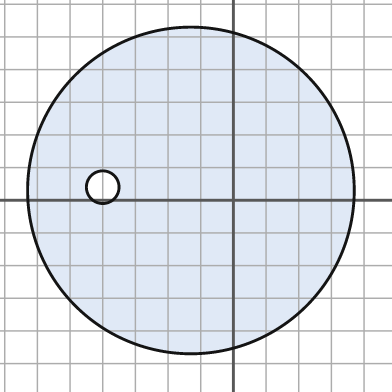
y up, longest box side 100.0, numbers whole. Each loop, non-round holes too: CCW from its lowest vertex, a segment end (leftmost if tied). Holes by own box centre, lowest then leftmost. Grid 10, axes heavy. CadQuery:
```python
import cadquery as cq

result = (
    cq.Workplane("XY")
    .moveTo(-13.0, 3.0)
    .circle(50.0)
    .moveTo(-40.0, 4.0)
    .circle(5.0)
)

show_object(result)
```